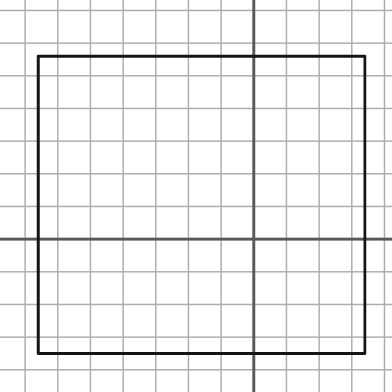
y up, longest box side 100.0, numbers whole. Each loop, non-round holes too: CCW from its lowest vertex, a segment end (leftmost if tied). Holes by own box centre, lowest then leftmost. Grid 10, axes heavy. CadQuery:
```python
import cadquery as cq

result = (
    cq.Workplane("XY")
    .moveTo(-66.0, -35.0)
    .lineTo(34.0, -35.0)
    .lineTo(34.0, 56.0)
    .lineTo(-66.0, 56.0)
    .close()
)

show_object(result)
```